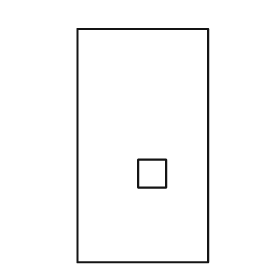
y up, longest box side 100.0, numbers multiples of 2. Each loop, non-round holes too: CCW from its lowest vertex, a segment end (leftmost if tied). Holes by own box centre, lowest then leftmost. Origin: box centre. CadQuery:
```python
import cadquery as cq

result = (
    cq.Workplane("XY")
    .moveTo(-28.0, -50.0)
    .lineTo(28.0, -50.0)
    .lineTo(28.0, 50.0)
    .lineTo(-28.0, 50.0)
    .close()
    .moveTo(-2.0, -18.0)
    .lineTo(10.0, -18.0)
    .lineTo(10.0, -6.0)
    .lineTo(-2.0, -6.0)
    .close()
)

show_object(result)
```